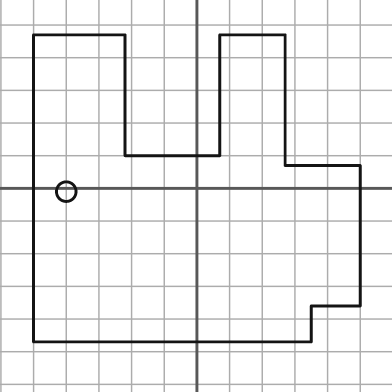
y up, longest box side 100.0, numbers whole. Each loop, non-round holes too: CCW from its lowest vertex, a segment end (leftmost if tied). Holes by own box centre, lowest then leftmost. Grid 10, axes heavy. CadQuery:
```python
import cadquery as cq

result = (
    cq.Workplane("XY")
    .moveTo(-50.0, -47.0)
    .lineTo(35.0, -47.0)
    .lineTo(35.0, -36.0)
    .lineTo(50.0, -36.0)
    .lineTo(50.0, 7.0)
    .lineTo(27.0, 7.0)
    .lineTo(27.0, 47.0)
    .lineTo(7.0, 47.0)
    .lineTo(7.0, 10.0)
    .lineTo(-22.0, 10.0)
    .lineTo(-22.0, 47.0)
    .lineTo(-50.0, 47.0)
    .close()
    .moveTo(-40.0, -1.0)
    .circle(3.0)
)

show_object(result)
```